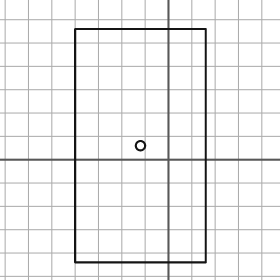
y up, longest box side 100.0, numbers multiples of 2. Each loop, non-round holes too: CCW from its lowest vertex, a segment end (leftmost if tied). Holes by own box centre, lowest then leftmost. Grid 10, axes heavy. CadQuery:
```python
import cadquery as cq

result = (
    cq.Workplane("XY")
    .moveTo(-40.0, -44.0)
    .lineTo(16.0, -44.0)
    .lineTo(16.0, 56.0)
    .lineTo(-40.0, 56.0)
    .close()
    .moveTo(-12.0, 6.0)
    .circle(2.0)
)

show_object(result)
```